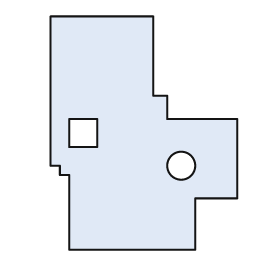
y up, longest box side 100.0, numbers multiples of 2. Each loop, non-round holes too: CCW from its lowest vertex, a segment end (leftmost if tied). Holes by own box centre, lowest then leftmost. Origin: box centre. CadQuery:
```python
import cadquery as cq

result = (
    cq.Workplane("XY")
    .moveTo(-32.0, -50.0)
    .lineTo(22.0, -50.0)
    .lineTo(22.0, -28.0)
    .lineTo(40.0, -28.0)
    .lineTo(40.0, 6.0)
    .lineTo(10.0, 6.0)
    .lineTo(10.0, 16.0)
    .lineTo(4.0, 16.0)
    .lineTo(4.0, 50.0)
    .lineTo(-40.0, 50.0)
    .lineTo(-40.0, -14.0)
    .lineTo(-36.0, -14.0)
    .lineTo(-36.0, -18.0)
    .lineTo(-32.0, -18.0)
    .close()
    .moveTo(16.0, -14.0)
    .circle(6.0)
    .moveTo(-32.0, -6.0)
    .lineTo(-20.0, -6.0)
    .lineTo(-20.0, 6.0)
    .lineTo(-32.0, 6.0)
    .close()
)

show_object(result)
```